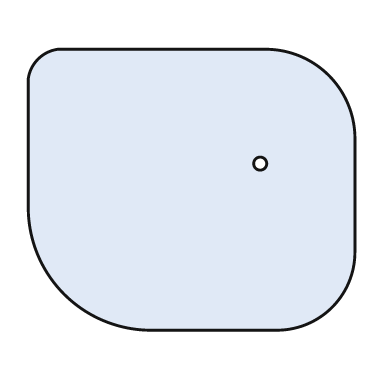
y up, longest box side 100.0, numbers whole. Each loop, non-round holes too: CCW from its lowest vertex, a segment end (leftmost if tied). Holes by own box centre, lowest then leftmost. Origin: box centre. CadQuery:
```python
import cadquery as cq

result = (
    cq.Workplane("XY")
    .moveTo(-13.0, -43.0)
    .lineTo(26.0, -43.0)
    .threePointArc((43.0, -36.0), (50.0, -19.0))
    .lineTo(50.0, 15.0)
    .threePointArc((42.0, 35.0), (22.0, 43.0))
    .lineTo(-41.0, 43.0)
    .threePointArc((-47.0, 40.0), (-50.0, 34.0))
    .lineTo(-50.0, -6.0)
    .threePointArc((-39.0, -32.0), (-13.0, -43.0))
    .close()
    .moveTo(21.0, 8.0)
    .circle(2.0)
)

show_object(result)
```